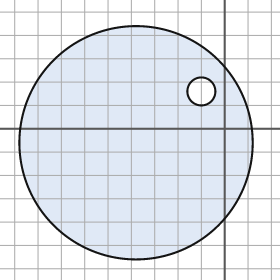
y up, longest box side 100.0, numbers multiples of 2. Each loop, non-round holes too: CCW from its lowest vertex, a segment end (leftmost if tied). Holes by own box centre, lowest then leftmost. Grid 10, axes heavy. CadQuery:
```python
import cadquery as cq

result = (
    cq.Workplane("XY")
    .moveTo(-38.0, -6.0)
    .circle(50.0)
    .moveTo(-10.0, 16.0)
    .circle(6.0)
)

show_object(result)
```